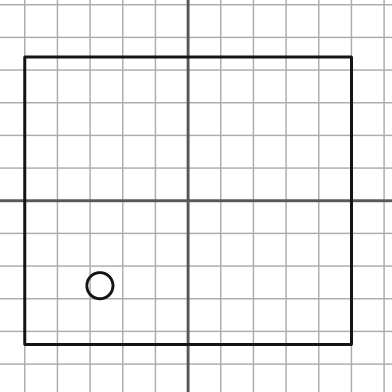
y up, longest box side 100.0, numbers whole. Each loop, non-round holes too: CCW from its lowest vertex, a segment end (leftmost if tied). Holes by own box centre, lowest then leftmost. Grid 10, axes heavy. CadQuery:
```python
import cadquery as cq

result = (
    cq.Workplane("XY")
    .moveTo(-50.0, -44.0)
    .lineTo(50.0, -44.0)
    .lineTo(50.0, 44.0)
    .lineTo(-50.0, 44.0)
    .close()
    .moveTo(-27.0, -26.0)
    .circle(4.0)
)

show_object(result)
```